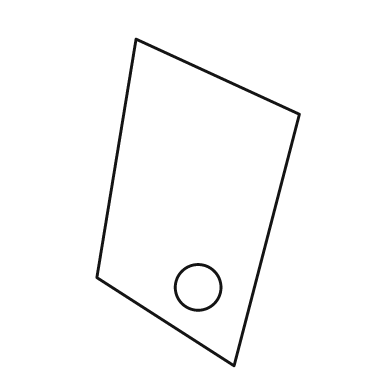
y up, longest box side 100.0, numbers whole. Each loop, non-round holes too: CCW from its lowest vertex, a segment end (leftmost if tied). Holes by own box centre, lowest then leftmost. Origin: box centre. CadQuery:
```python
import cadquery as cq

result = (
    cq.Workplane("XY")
    .moveTo(11.0, -50.0)
    .lineTo(31.0, 27.0)
    .lineTo(-19.0, 50.0)
    .lineTo(-31.0, -23.0)
    .close()
    .moveTo(0.0, -26.0)
    .circle(7.0)
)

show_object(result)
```